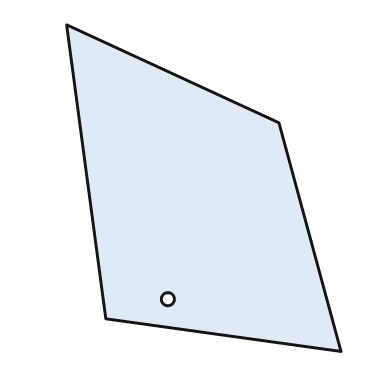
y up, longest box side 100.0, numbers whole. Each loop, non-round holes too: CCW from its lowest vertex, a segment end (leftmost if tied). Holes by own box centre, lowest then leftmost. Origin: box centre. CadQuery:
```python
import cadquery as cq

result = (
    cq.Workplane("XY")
    .moveTo(42.0, -50.0)
    .lineTo(23.0, 20.0)
    .lineTo(-42.0, 50.0)
    .lineTo(-30.0, -40.0)
    .close()
    .moveTo(-11.0, -34.0)
    .circle(2.0)
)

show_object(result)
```